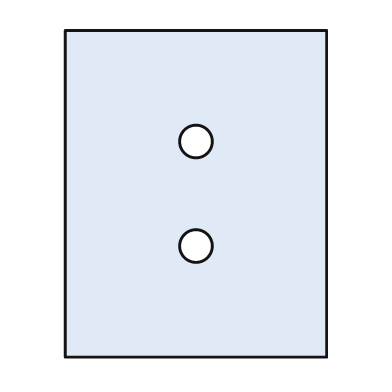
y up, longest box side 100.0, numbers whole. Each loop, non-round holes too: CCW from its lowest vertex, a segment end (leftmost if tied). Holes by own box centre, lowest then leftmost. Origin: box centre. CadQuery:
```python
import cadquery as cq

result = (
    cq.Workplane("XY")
    .moveTo(-40.0, -50.0)
    .lineTo(40.0, -50.0)
    .lineTo(40.0, 50.0)
    .lineTo(-40.0, 50.0)
    .close()
    .moveTo(0.0, -16.0)
    .circle(5.0)
    .moveTo(0.0, 16.0)
    .circle(5.0)
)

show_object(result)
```